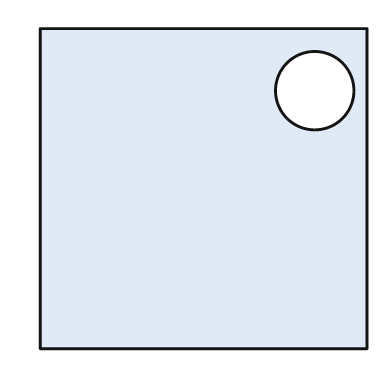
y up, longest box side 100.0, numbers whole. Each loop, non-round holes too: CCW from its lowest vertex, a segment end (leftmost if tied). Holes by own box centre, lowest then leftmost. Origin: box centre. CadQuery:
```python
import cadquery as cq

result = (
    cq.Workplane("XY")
    .moveTo(-50.0, -49.0)
    .lineTo(50.0, -49.0)
    .lineTo(50.0, 49.0)
    .lineTo(-50.0, 49.0)
    .close()
    .moveTo(34.0, 30.0)
    .circle(12.0)
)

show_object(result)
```